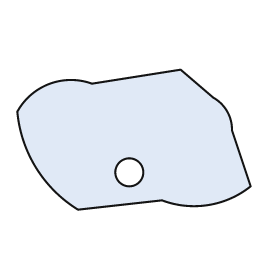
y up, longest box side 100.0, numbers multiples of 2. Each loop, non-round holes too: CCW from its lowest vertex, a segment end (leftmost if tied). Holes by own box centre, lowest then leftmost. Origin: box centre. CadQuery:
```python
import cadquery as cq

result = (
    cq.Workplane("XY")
    .moveTo(-24.0, -30.0)
    .lineTo(12.0, -26.0)
    .threePointArc((32.0, -28.0), (50.0, -20.0))
    .lineTo(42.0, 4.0)
    .threePointArc((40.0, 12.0), (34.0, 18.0))
    .lineTo(20.0, 30.0)
    .lineTo(-18.0, 24.0)
    .threePointArc((-36.0, 24.0), (-50.0, 12.0))
    .threePointArc((-42.0, -12.0), (-24.0, -30.0))
    .close()
    .moveTo(-2.0, -14.0)
    .circle(6.0)
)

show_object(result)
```